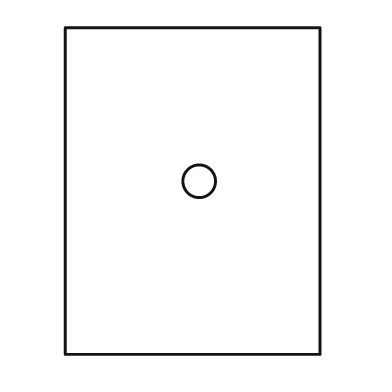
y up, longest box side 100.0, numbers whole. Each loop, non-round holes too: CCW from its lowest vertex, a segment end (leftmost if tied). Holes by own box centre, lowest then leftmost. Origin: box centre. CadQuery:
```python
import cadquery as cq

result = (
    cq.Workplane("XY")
    .moveTo(-39.0, -50.0)
    .lineTo(39.0, -50.0)
    .lineTo(39.0, 50.0)
    .lineTo(-39.0, 50.0)
    .close()
    .moveTo(2.0, 3.0)
    .circle(5.0)
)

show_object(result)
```